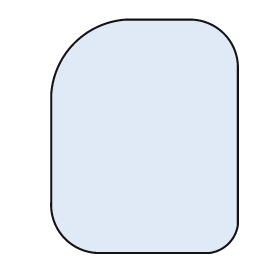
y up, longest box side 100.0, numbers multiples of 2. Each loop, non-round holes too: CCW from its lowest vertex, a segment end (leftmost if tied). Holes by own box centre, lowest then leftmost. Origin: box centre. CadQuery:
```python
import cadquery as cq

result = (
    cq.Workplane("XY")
    .moveTo(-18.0, -50.0)
    .lineTo(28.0, -50.0)
    .threePointArc((36.0, -46.0), (40.0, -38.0))
    .lineTo(40.0, 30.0)
    .threePointArc((34.0, 44.0), (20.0, 50.0))
    .lineTo(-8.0, 50.0)
    .threePointArc((-30.0, 40.0), (-40.0, 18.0))
    .lineTo(-40.0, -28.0)
    .threePointArc((-34.0, -44.0), (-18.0, -50.0))
    .close()
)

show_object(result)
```